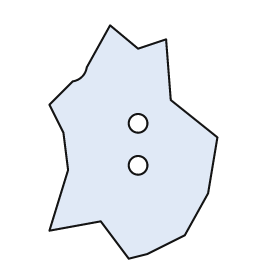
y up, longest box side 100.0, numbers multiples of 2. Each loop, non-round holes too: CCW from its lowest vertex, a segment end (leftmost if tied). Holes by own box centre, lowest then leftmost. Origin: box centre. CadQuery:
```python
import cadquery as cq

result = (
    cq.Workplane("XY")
    .moveTo(-2.0, -50.0)
    .lineTo(6.0, -48.0)
    .lineTo(22.0, -40.0)
    .lineTo(32.0, -22.0)
    .lineTo(36.0, 2.0)
    .lineTo(16.0, 18.0)
    .lineTo(14.0, 44.0)
    .lineTo(2.0, 40.0)
    .lineTo(-10.0, 50.0)
    .lineTo(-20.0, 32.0)
    .threePointArc((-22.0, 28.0), (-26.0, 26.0))
    .lineTo(-36.0, 16.0)
    .lineTo(-30.0, 4.0)
    .lineTo(-28.0, -12.0)
    .lineTo(-36.0, -38.0)
    .lineTo(-14.0, -34.0)
    .close()
    .moveTo(2.0, -10.0)
    .circle(4.0)
    .moveTo(2.0, 8.0)
    .circle(4.0)
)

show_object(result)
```